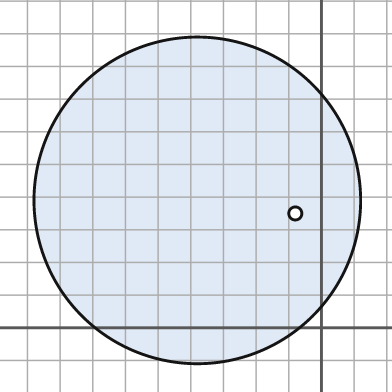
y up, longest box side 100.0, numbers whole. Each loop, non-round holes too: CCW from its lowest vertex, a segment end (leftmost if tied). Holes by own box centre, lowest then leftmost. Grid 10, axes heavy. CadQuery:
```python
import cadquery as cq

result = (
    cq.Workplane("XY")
    .moveTo(-38.0, 39.0)
    .circle(50.0)
    .moveTo(-8.0, 35.0)
    .circle(2.0)
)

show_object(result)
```